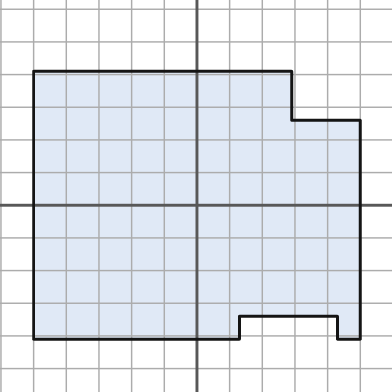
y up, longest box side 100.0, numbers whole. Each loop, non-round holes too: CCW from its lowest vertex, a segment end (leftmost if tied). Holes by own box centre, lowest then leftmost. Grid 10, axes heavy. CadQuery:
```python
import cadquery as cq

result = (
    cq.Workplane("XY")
    .moveTo(-50.0, -41.0)
    .lineTo(13.0, -41.0)
    .lineTo(13.0, -34.0)
    .lineTo(43.0, -34.0)
    .lineTo(43.0, -41.0)
    .lineTo(50.0, -41.0)
    .lineTo(50.0, 26.0)
    .lineTo(29.0, 26.0)
    .lineTo(29.0, 41.0)
    .lineTo(-50.0, 41.0)
    .close()
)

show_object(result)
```